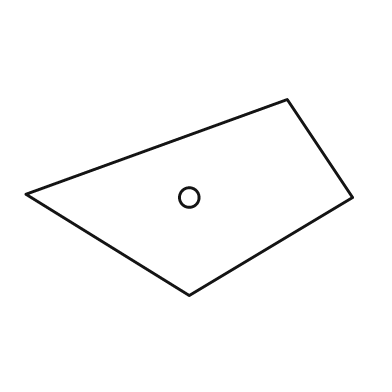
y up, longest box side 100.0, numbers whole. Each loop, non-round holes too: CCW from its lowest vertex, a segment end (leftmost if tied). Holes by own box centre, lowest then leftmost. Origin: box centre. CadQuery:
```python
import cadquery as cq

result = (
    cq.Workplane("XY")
    .moveTo(0.0, -30.0)
    .lineTo(50.0, 0.0)
    .lineTo(30.0, 30.0)
    .lineTo(-50.0, 1.0)
    .close()
    .moveTo(0.0, 0.0)
    .circle(3.0)
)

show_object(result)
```